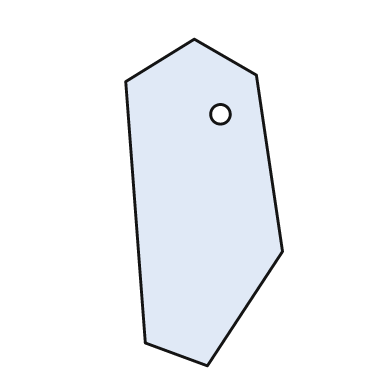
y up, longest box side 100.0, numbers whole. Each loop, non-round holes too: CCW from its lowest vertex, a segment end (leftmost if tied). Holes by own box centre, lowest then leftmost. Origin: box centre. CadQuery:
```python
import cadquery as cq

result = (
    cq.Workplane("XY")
    .moveTo(1.0, -50.0)
    .lineTo(24.0, -15.0)
    .lineTo(16.0, 39.0)
    .lineTo(-3.0, 50.0)
    .lineTo(-24.0, 37.0)
    .lineTo(-18.0, -43.0)
    .close()
    .moveTo(5.0, 27.0)
    .circle(3.0)
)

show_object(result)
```